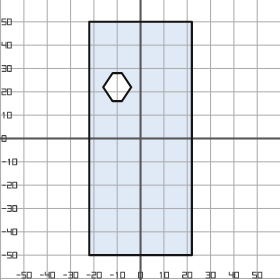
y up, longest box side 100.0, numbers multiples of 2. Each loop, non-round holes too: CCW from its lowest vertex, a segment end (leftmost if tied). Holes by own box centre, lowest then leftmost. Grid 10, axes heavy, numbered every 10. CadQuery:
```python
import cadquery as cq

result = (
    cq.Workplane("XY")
    .moveTo(-22.0, -50.0)
    .lineTo(22.0, -50.0)
    .lineTo(22.0, 50.0)
    .lineTo(-22.0, 50.0)
    .close()
    .moveTo(-12.0, 16.0)
    .lineTo(-8.0, 16.0)
    .lineTo(-4.0, 22.0)
    .lineTo(-8.0, 28.0)
    .lineTo(-12.0, 28.0)
    .lineTo(-16.0, 22.0)
    .close()
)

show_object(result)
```